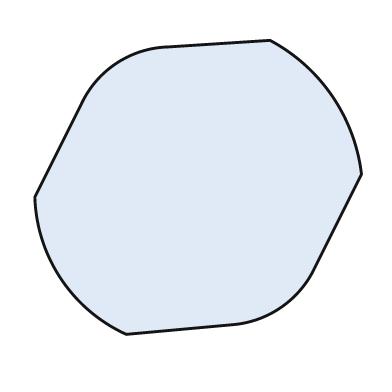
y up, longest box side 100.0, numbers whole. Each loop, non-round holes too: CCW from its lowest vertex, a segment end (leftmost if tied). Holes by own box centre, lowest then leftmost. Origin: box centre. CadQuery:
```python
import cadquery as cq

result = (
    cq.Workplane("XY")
    .moveTo(-22.0, -45.0)
    .lineTo(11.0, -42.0)
    .threePointArc((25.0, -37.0), (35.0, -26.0))
    .lineTo(50.0, 4.0)
    .threePointArc((41.0, 28.0), (22.0, 45.0))
    .lineTo(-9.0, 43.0)
    .threePointArc((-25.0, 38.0), (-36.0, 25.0))
    .lineTo(-50.0, -3.0)
    .threePointArc((-42.0, -28.0), (-22.0, -45.0))
    .close()
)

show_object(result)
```